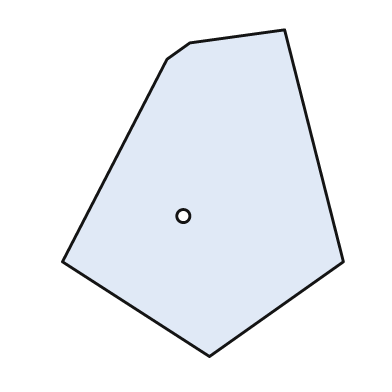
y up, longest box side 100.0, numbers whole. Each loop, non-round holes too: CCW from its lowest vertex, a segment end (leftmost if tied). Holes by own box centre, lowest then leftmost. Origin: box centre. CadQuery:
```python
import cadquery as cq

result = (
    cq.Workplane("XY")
    .moveTo(2.0, -50.0)
    .lineTo(43.0, -21.0)
    .lineTo(25.0, 50.0)
    .lineTo(-4.0, 46.0)
    .lineTo(-11.0, 41.0)
    .lineTo(-43.0, -21.0)
    .close()
    .moveTo(-6.0, -7.0)
    .circle(2.0)
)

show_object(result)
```